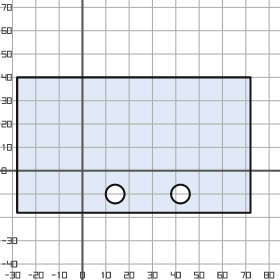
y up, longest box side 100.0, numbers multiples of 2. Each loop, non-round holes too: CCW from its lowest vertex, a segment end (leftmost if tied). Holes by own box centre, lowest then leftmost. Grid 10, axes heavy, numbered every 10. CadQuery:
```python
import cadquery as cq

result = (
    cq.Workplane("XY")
    .moveTo(-28.0, -18.0)
    .lineTo(72.0, -18.0)
    .lineTo(72.0, 40.0)
    .lineTo(-28.0, 40.0)
    .close()
    .moveTo(14.0, -10.0)
    .circle(4.0)
    .moveTo(42.0, -10.0)
    .circle(4.0)
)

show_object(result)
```